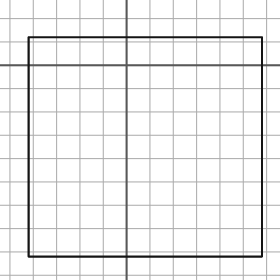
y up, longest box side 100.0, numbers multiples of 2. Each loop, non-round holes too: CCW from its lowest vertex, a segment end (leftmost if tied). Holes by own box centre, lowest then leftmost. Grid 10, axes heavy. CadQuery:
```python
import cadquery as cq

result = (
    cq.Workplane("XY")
    .moveTo(-42.0, -82.0)
    .lineTo(58.0, -82.0)
    .lineTo(58.0, 12.0)
    .lineTo(-42.0, 12.0)
    .close()
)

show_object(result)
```